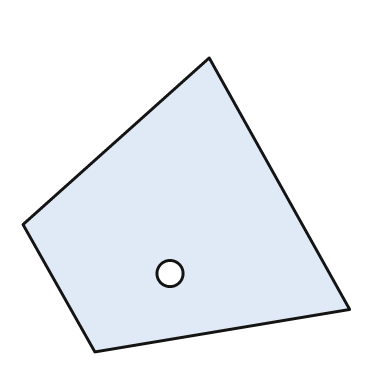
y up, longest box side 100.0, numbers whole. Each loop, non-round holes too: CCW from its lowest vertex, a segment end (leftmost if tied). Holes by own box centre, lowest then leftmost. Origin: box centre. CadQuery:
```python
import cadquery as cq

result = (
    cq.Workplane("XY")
    .moveTo(-28.0, -45.0)
    .lineTo(50.0, -32.0)
    .lineTo(7.0, 45.0)
    .lineTo(-50.0, -6.0)
    .close()
    .moveTo(-5.0, -21.0)
    .circle(4.0)
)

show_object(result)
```